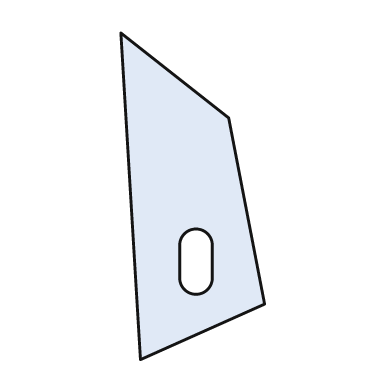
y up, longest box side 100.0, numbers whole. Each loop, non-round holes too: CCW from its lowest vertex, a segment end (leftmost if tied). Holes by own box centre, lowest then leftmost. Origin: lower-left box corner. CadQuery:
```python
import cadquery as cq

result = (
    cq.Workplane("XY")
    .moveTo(6.0, 0.0)
    .lineTo(44.0, 17.0)
    .lineTo(33.0, 74.0)
    .lineTo(0.0, 100.0)
    .close()
    .moveTo(18.0, 25.0)
    .threePointArc((23.0, 20.0), (28.0, 25.0))
    .lineTo(28.0, 35.0)
    .threePointArc((23.0, 40.0), (18.0, 35.0))
    .close()
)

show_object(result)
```